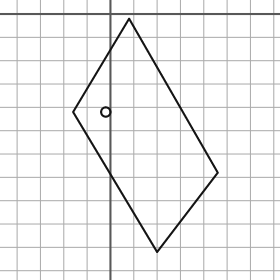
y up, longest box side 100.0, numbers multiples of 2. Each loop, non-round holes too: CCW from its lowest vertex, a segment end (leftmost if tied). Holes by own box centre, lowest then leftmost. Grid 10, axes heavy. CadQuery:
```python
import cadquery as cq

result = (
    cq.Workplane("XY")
    .moveTo(20.0, -102.0)
    .lineTo(46.0, -68.0)
    .lineTo(8.0, -2.0)
    .lineTo(-16.0, -42.0)
    .close()
    .moveTo(-2.0, -42.0)
    .circle(2.0)
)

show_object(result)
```